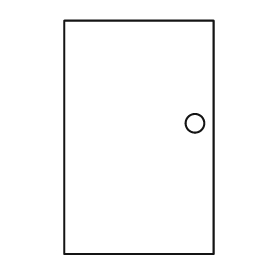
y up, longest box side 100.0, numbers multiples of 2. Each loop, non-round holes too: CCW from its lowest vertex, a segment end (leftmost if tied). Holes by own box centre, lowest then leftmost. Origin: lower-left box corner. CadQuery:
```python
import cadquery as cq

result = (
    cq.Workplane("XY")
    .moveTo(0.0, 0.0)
    .lineTo(64.0, 0.0)
    .lineTo(64.0, 100.0)
    .lineTo(0.0, 100.0)
    .close()
    .moveTo(56.0, 56.0)
    .circle(4.0)
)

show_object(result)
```